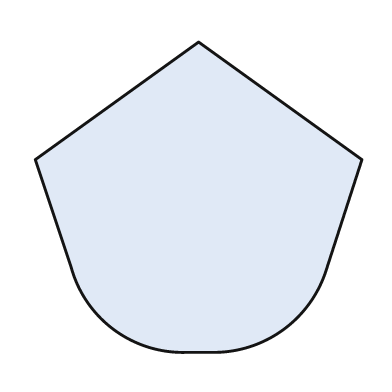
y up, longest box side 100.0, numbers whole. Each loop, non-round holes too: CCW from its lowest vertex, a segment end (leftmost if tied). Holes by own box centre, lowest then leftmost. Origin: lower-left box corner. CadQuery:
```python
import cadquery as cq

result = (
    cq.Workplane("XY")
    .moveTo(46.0, 0.0)
    .lineTo(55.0, 0.0)
    .threePointArc((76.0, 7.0), (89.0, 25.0))
    .lineTo(100.0, 59.0)
    .lineTo(50.0, 95.0)
    .lineTo(0.0, 59.0)
    .lineTo(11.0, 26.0)
    .threePointArc((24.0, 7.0), (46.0, 0.0))
    .close()
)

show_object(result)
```